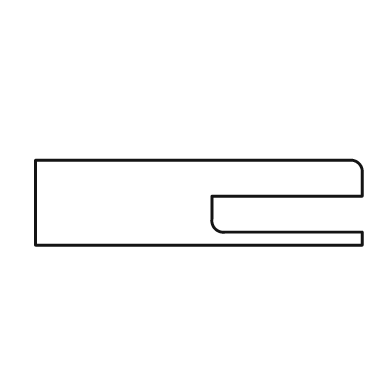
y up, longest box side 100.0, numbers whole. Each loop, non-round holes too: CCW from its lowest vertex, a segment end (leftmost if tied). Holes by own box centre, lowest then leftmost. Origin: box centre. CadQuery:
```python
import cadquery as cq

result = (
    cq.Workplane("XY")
    .moveTo(-50.0, -13.0)
    .lineTo(50.0, -13.0)
    .lineTo(50.0, -9.0)
    .lineTo(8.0, -9.0)
    .threePointArc((5.0, -8.0), (4.0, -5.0))
    .lineTo(4.0, 2.0)
    .lineTo(50.0, 2.0)
    .lineTo(50.0, 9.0)
    .threePointArc((49.0, 12.0), (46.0, 13.0))
    .lineTo(-50.0, 13.0)
    .close()
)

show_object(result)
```